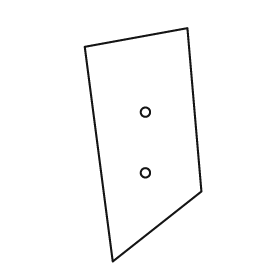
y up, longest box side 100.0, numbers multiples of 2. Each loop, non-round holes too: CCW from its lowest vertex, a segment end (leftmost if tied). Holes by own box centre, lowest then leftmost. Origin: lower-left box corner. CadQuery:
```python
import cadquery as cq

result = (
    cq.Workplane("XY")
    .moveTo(12.0, 0.0)
    .lineTo(50.0, 30.0)
    .lineTo(44.0, 100.0)
    .lineTo(0.0, 92.0)
    .close()
    .moveTo(26.0, 38.0)
    .circle(2.0)
    .moveTo(26.0, 64.0)
    .circle(2.0)
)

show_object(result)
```